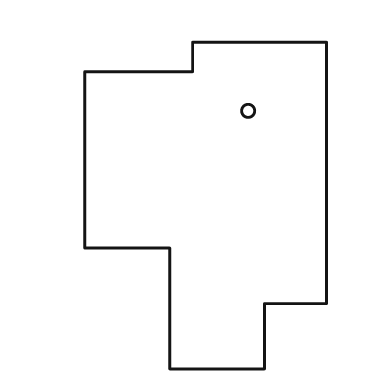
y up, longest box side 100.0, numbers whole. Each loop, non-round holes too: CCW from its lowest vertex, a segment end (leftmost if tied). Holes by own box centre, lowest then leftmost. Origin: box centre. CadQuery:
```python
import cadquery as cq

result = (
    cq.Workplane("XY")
    .moveTo(-11.0, -50.0)
    .lineTo(18.0, -50.0)
    .lineTo(18.0, -30.0)
    .lineTo(37.0, -30.0)
    .lineTo(37.0, 50.0)
    .lineTo(-4.0, 50.0)
    .lineTo(-4.0, 41.0)
    .lineTo(-37.0, 41.0)
    .lineTo(-37.0, -13.0)
    .lineTo(-11.0, -13.0)
    .close()
    .moveTo(13.0, 29.0)
    .circle(2.0)
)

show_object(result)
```